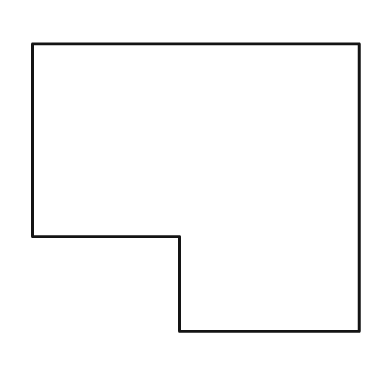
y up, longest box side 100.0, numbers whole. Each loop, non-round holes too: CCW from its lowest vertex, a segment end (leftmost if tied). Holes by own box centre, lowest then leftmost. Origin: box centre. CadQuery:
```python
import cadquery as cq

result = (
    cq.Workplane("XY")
    .moveTo(-5.0, -44.0)
    .lineTo(50.0, -44.0)
    .lineTo(50.0, 44.0)
    .lineTo(-50.0, 44.0)
    .lineTo(-50.0, -15.0)
    .lineTo(-5.0, -15.0)
    .close()
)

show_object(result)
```